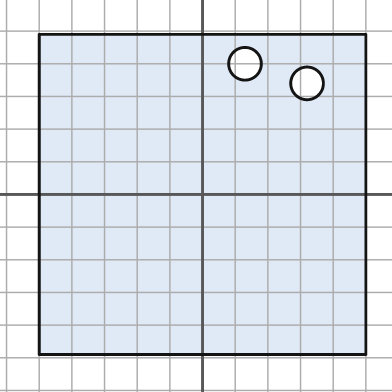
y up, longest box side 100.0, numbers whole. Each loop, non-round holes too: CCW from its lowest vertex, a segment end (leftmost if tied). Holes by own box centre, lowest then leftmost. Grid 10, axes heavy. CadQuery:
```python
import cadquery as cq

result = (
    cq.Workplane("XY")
    .moveTo(-50.0, -49.0)
    .lineTo(50.0, -49.0)
    .lineTo(50.0, 49.0)
    .lineTo(-50.0, 49.0)
    .close()
    .moveTo(32.0, 34.0)
    .circle(5.0)
    .moveTo(13.0, 40.0)
    .circle(5.0)
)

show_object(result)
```